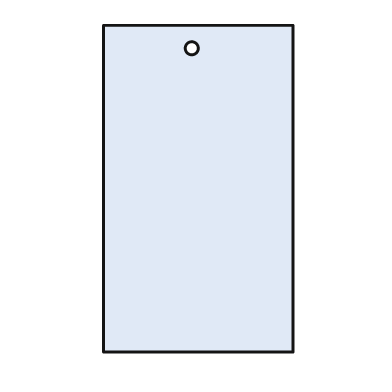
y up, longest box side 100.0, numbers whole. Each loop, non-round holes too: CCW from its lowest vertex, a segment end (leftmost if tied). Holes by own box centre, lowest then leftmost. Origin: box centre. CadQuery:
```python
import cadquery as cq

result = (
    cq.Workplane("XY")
    .moveTo(-29.0, -50.0)
    .lineTo(29.0, -50.0)
    .lineTo(29.0, 50.0)
    .lineTo(-29.0, 50.0)
    .close()
    .moveTo(-2.0, 43.0)
    .circle(2.0)
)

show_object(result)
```